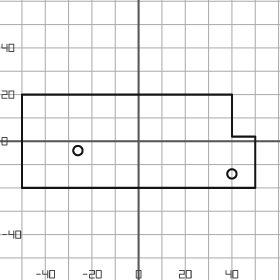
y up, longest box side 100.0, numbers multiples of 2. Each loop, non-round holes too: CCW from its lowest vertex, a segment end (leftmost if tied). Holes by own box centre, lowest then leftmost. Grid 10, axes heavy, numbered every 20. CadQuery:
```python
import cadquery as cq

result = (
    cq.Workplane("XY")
    .moveTo(-50.0, -20.0)
    .lineTo(50.0, -20.0)
    .lineTo(50.0, 2.0)
    .lineTo(40.0, 2.0)
    .lineTo(40.0, 20.0)
    .lineTo(-50.0, 20.0)
    .close()
    .moveTo(40.0, -14.0)
    .circle(2.0)
    .moveTo(-26.0, -4.0)
    .circle(2.0)
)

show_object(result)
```